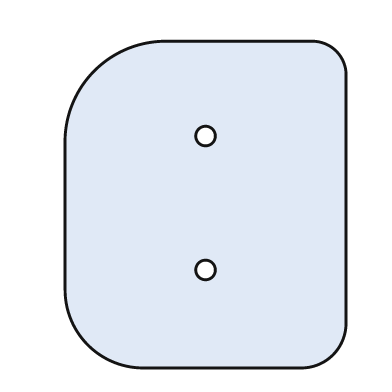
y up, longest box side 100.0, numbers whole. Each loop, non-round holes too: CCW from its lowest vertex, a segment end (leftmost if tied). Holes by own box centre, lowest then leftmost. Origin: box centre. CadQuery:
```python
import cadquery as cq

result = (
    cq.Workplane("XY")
    .moveTo(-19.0, -50.0)
    .lineTo(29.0, -50.0)
    .threePointArc((39.0, -46.0), (43.0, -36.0))
    .lineTo(43.0, 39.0)
    .threePointArc((40.0, 47.0), (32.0, 50.0))
    .lineTo(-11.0, 50.0)
    .threePointArc((-34.0, 41.0), (-43.0, 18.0))
    .lineTo(-43.0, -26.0)
    .threePointArc((-36.0, -43.0), (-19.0, -50.0))
    .close()
    .moveTo(0.0, -20.0)
    .circle(3.0)
    .moveTo(0.0, 21.0)
    .circle(3.0)
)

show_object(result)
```